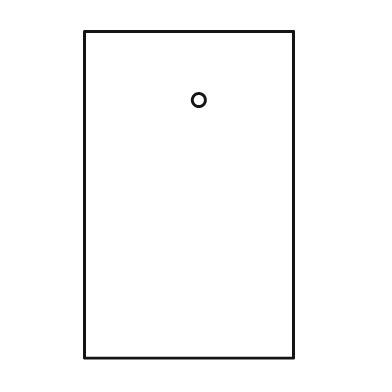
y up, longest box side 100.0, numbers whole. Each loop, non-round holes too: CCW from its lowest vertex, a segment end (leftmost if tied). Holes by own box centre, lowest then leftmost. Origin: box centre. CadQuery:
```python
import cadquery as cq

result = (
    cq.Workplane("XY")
    .moveTo(-32.0, -50.0)
    .lineTo(32.0, -50.0)
    .lineTo(32.0, 50.0)
    .lineTo(-32.0, 50.0)
    .close()
    .moveTo(3.0, 29.0)
    .circle(2.0)
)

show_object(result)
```